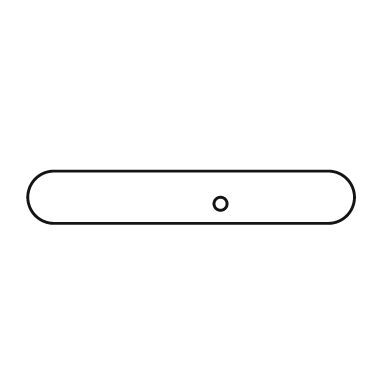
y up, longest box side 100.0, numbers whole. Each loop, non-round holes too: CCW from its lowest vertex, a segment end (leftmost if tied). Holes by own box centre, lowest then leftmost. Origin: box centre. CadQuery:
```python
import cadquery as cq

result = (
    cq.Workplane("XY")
    .moveTo(-42.0, -8.0)
    .lineTo(42.0, -8.0)
    .threePointArc((50.0, 0.0), (42.0, 8.0))
    .lineTo(-42.0, 8.0)
    .threePointArc((-50.0, 0.0), (-42.0, -8.0))
    .close()
    .moveTo(9.0, -2.0)
    .circle(2.0)
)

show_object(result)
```